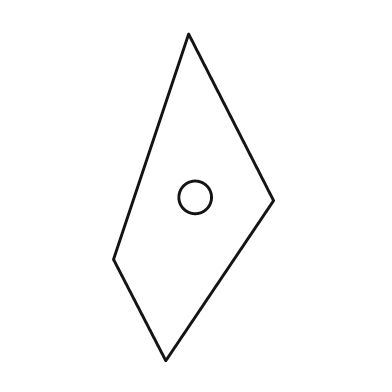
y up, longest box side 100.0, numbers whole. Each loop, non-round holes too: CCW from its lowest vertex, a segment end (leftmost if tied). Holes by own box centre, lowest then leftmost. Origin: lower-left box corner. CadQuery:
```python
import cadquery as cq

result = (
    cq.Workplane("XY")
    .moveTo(16.0, 0.0)
    .lineTo(49.0, 49.0)
    .lineTo(23.0, 100.0)
    .lineTo(0.0, 31.0)
    .close()
    .moveTo(25.0, 50.0)
    .circle(5.0)
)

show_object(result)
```